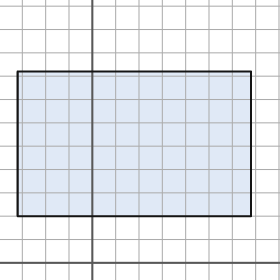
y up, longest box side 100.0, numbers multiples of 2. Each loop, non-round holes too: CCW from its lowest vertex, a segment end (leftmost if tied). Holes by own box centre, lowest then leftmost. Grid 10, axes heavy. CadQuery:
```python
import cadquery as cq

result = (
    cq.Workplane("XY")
    .moveTo(-32.0, 20.0)
    .lineTo(68.0, 20.0)
    .lineTo(68.0, 82.0)
    .lineTo(-32.0, 82.0)
    .close()
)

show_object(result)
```